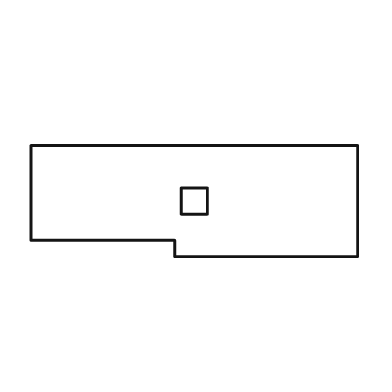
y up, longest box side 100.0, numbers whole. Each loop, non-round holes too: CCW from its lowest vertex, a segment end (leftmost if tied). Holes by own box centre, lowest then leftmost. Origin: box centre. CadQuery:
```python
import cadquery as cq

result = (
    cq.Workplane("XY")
    .moveTo(-6.0, -17.0)
    .lineTo(50.0, -17.0)
    .lineTo(50.0, 17.0)
    .lineTo(-50.0, 17.0)
    .lineTo(-50.0, -12.0)
    .lineTo(-6.0, -12.0)
    .close()
    .moveTo(-4.0, -4.0)
    .lineTo(4.0, -4.0)
    .lineTo(4.0, 4.0)
    .lineTo(-4.0, 4.0)
    .close()
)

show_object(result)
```